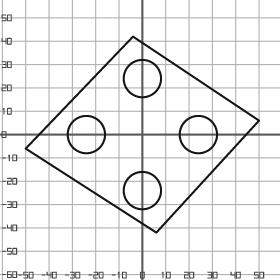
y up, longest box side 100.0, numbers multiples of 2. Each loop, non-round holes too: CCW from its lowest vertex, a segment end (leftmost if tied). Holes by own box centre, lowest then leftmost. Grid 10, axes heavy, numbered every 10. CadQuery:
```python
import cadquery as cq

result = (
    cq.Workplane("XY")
    .moveTo(6.0, -42.0)
    .lineTo(50.0, 6.0)
    .lineTo(-4.0, 42.0)
    .lineTo(-50.0, -6.0)
    .close()
    .moveTo(0.0, -24.0)
    .circle(8.0)
    .moveTo(-24.0, 0.0)
    .circle(8.0)
    .moveTo(24.0, 0.0)
    .circle(8.0)
    .moveTo(0.0, 24.0)
    .circle(8.0)
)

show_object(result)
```